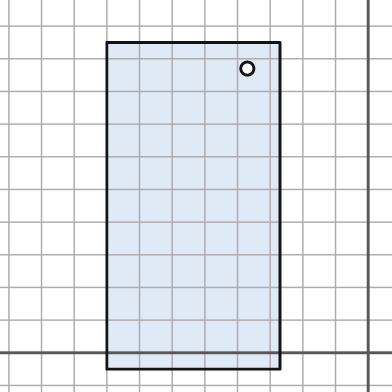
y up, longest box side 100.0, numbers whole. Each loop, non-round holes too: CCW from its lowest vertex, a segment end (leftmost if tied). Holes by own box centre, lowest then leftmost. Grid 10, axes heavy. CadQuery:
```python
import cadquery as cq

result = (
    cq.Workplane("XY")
    .moveTo(-80.0, -5.0)
    .lineTo(-27.0, -5.0)
    .lineTo(-27.0, 95.0)
    .lineTo(-80.0, 95.0)
    .close()
    .moveTo(-37.0, 87.0)
    .circle(2.0)
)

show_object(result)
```